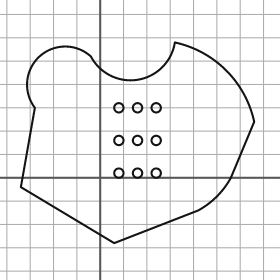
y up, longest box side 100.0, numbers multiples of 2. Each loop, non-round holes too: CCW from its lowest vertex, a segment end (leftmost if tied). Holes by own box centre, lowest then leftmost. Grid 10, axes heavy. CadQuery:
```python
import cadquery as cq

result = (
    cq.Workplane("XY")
    .moveTo(6.0, -28.0)
    .lineTo(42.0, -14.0)
    .threePointArc((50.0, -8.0), (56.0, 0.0))
    .lineTo(66.0, 24.0)
    .threePointArc((54.0, 46.0), (32.0, 58.0))
    .threePointArc((16.0, 42.0), (-4.0, 52.0))
    .threePointArc((-26.0, 52.0), (-28.0, 30.0))
    .lineTo(-34.0, -4.0)
    .close()
    .moveTo(8.0, 2.0)
    .circle(2.0)
    .moveTo(16.0, 2.0)
    .circle(2.0)
    .moveTo(24.0, 2.0)
    .circle(2.0)
    .moveTo(8.0, 16.0)
    .circle(2.0)
    .moveTo(16.0, 16.0)
    .circle(2.0)
    .moveTo(24.0, 16.0)
    .circle(2.0)
    .moveTo(8.0, 30.0)
    .circle(2.0)
    .moveTo(16.0, 30.0)
    .circle(2.0)
    .moveTo(24.0, 30.0)
    .circle(2.0)
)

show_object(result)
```